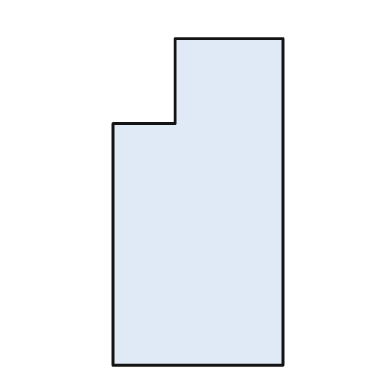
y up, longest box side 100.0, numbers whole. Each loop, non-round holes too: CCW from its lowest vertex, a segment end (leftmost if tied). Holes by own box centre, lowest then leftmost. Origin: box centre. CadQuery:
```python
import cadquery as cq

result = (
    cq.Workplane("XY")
    .moveTo(-26.0, -50.0)
    .lineTo(26.0, -50.0)
    .lineTo(26.0, 50.0)
    .lineTo(-7.0, 50.0)
    .lineTo(-7.0, 24.0)
    .lineTo(-26.0, 24.0)
    .close()
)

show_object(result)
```